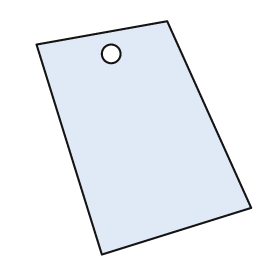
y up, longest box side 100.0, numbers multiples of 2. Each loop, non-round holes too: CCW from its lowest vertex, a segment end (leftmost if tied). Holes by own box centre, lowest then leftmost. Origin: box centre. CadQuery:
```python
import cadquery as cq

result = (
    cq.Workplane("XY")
    .moveTo(-18.0, -50.0)
    .lineTo(46.0, -30.0)
    .lineTo(10.0, 50.0)
    .lineTo(-46.0, 40.0)
    .close()
    .moveTo(-14.0, 36.0)
    .circle(4.0)
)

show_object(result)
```